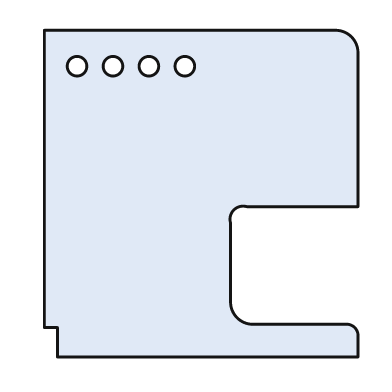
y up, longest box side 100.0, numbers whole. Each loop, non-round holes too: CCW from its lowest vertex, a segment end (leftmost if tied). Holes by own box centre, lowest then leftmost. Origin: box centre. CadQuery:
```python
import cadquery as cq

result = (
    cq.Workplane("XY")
    .moveTo(-44.0, -50.0)
    .lineTo(48.0, -50.0)
    .lineTo(48.0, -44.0)
    .threePointArc((47.0, -41.0), (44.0, -40.0))
    .lineTo(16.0, -40.0)
    .threePointArc((11.0, -38.0), (9.0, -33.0))
    .lineTo(9.0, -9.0)
    .threePointArc((10.0, -5.0), (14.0, -4.0))
    .lineTo(48.0, -4.0)
    .lineTo(48.0, 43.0)
    .threePointArc((46.0, 48.0), (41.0, 50.0))
    .lineTo(-48.0, 50.0)
    .lineTo(-48.0, -41.0)
    .lineTo(-44.0, -41.0)
    .close()
    .moveTo(-38.0, 39.0)
    .circle(3.0)
    .moveTo(-27.0, 39.0)
    .circle(3.0)
    .moveTo(-16.0, 39.0)
    .circle(3.0)
    .moveTo(-5.0, 39.0)
    .circle(3.0)
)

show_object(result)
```